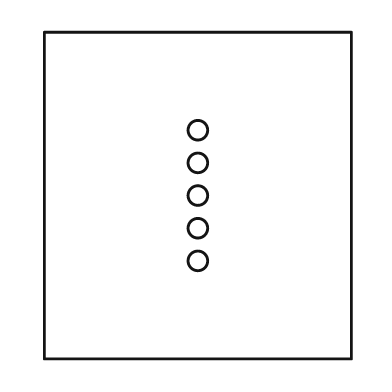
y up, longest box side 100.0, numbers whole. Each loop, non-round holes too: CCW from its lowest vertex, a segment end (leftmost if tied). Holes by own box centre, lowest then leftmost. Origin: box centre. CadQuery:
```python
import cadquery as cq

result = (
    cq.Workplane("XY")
    .moveTo(-47.0, -50.0)
    .lineTo(47.0, -50.0)
    .lineTo(47.0, 50.0)
    .lineTo(-47.0, 50.0)
    .close()
    .moveTo(0.0, -20.0)
    .circle(3.0)
    .moveTo(0.0, -10.0)
    .circle(3.0)
    .moveTo(0.0, 0.0)
    .circle(3.0)
    .moveTo(0.0, 10.0)
    .circle(3.0)
    .moveTo(0.0, 20.0)
    .circle(3.0)
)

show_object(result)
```